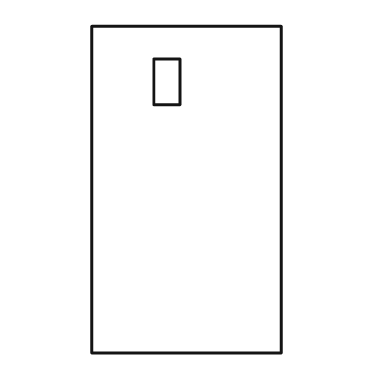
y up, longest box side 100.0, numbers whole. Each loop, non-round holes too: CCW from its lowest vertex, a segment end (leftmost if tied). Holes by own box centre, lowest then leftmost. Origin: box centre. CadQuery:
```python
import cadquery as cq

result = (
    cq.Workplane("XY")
    .moveTo(-29.0, -50.0)
    .lineTo(29.0, -50.0)
    .lineTo(29.0, 50.0)
    .lineTo(-29.0, 50.0)
    .close()
    .moveTo(-10.0, 26.0)
    .lineTo(-2.0, 26.0)
    .lineTo(-2.0, 40.0)
    .lineTo(-10.0, 40.0)
    .close()
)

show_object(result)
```